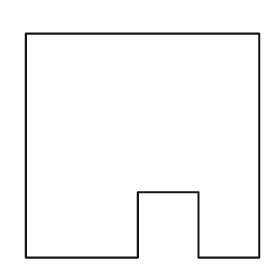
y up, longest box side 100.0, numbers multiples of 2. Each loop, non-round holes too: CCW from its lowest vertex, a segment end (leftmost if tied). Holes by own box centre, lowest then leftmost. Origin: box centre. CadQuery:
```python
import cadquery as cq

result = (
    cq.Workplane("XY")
    .moveTo(-50.0, -48.0)
    .lineTo(-2.0, -48.0)
    .lineTo(-2.0, -20.0)
    .lineTo(24.0, -20.0)
    .lineTo(24.0, -48.0)
    .lineTo(50.0, -48.0)
    .lineTo(50.0, 48.0)
    .lineTo(-50.0, 48.0)
    .close()
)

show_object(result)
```